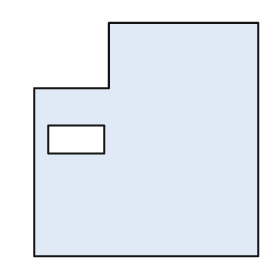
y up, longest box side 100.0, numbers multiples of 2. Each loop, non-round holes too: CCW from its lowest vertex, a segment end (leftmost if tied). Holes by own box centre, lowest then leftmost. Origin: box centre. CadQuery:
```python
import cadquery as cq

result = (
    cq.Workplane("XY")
    .moveTo(-48.0, -50.0)
    .lineTo(48.0, -50.0)
    .lineTo(48.0, 50.0)
    .lineTo(-16.0, 50.0)
    .lineTo(-16.0, 22.0)
    .lineTo(-48.0, 22.0)
    .close()
    .moveTo(-42.0, -6.0)
    .lineTo(-18.0, -6.0)
    .lineTo(-18.0, 6.0)
    .lineTo(-42.0, 6.0)
    .close()
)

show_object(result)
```